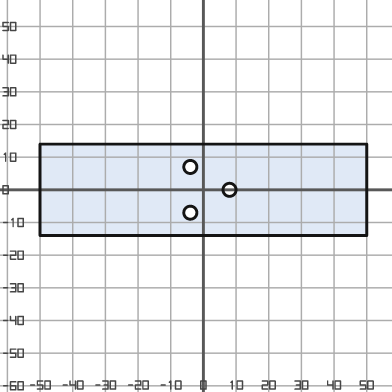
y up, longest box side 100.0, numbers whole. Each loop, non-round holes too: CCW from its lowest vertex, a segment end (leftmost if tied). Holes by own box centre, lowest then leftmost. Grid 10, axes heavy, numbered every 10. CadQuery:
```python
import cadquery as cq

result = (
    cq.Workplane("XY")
    .moveTo(-50.0, -14.0)
    .lineTo(50.0, -14.0)
    .lineTo(50.0, 14.0)
    .lineTo(-50.0, 14.0)
    .close()
    .moveTo(-4.0, -7.0)
    .circle(2.0)
    .moveTo(8.0, 0.0)
    .circle(2.0)
    .moveTo(-4.0, 7.0)
    .circle(2.0)
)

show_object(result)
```